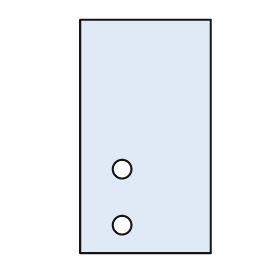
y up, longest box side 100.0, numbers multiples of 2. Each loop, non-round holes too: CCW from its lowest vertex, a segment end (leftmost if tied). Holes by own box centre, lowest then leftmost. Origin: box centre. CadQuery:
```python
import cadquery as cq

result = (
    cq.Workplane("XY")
    .moveTo(-28.0, -50.0)
    .lineTo(28.0, -50.0)
    .lineTo(28.0, 50.0)
    .lineTo(-28.0, 50.0)
    .close()
    .moveTo(-10.0, -38.0)
    .circle(4.0)
    .moveTo(-10.0, -14.0)
    .circle(4.0)
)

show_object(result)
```